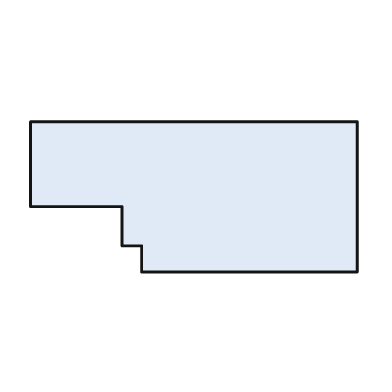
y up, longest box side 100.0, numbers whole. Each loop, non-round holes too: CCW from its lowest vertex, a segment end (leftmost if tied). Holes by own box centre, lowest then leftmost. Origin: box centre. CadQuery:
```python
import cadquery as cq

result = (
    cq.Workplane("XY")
    .moveTo(-16.0, -23.0)
    .lineTo(50.0, -23.0)
    .lineTo(50.0, 23.0)
    .lineTo(-50.0, 23.0)
    .lineTo(-50.0, -3.0)
    .lineTo(-22.0, -3.0)
    .lineTo(-22.0, -15.0)
    .lineTo(-16.0, -15.0)
    .close()
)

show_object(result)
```